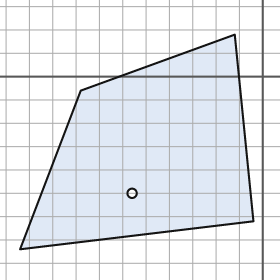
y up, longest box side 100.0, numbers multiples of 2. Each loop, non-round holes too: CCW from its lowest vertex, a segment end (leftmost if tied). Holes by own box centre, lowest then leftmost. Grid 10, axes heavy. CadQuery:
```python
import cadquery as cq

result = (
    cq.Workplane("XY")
    .moveTo(-104.0, -74.0)
    .lineTo(-4.0, -62.0)
    .lineTo(-12.0, 18.0)
    .lineTo(-78.0, -6.0)
    .close()
    .moveTo(-56.0, -50.0)
    .circle(2.0)
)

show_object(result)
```